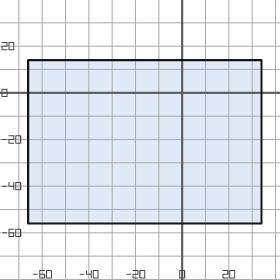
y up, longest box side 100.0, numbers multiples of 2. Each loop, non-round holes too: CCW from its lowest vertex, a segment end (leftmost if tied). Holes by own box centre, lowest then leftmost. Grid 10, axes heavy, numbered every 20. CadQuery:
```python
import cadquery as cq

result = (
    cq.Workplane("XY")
    .moveTo(-66.0, -56.0)
    .lineTo(34.0, -56.0)
    .lineTo(34.0, 14.0)
    .lineTo(-66.0, 14.0)
    .close()
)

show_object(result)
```